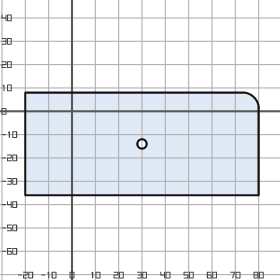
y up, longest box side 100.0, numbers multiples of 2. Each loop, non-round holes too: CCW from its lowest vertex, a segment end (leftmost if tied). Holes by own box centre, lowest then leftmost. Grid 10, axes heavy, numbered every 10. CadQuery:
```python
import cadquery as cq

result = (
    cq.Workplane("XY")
    .moveTo(-20.0, -36.0)
    .lineTo(80.0, -36.0)
    .lineTo(80.0, 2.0)
    .threePointArc((78.0, 6.0), (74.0, 8.0))
    .lineTo(-20.0, 8.0)
    .close()
    .moveTo(30.0, -14.0)
    .circle(2.0)
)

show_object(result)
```